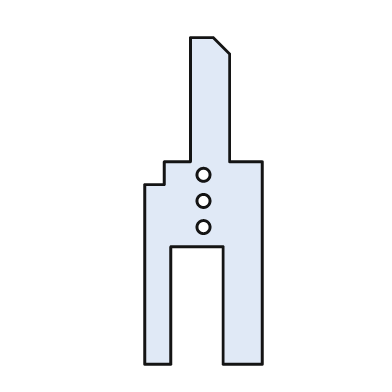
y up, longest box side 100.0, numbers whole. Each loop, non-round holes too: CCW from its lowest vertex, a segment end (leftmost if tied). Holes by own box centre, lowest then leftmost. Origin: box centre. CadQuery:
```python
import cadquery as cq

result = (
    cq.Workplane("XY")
    .moveTo(-18.0, -50.0)
    .lineTo(-10.0, -50.0)
    .lineTo(-10.0, -14.0)
    .lineTo(6.0, -14.0)
    .lineTo(6.0, -50.0)
    .lineTo(18.0, -50.0)
    .lineTo(18.0, 12.0)
    .lineTo(8.0, 12.0)
    .lineTo(8.0, 45.0)
    .lineTo(3.0, 50.0)
    .lineTo(-4.0, 50.0)
    .lineTo(-4.0, 12.0)
    .lineTo(-12.0, 12.0)
    .lineTo(-12.0, 5.0)
    .lineTo(-18.0, 5.0)
    .close()
    .moveTo(0.0, -8.0)
    .circle(2.0)
    .moveTo(0.0, 0.0)
    .circle(2.0)
    .moveTo(0.0, 8.0)
    .circle(2.0)
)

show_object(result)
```